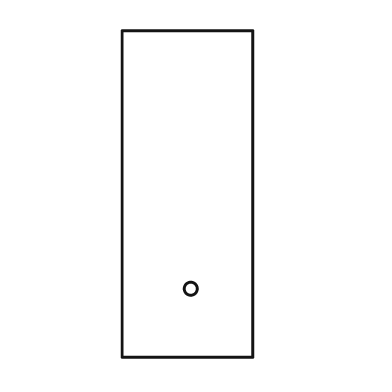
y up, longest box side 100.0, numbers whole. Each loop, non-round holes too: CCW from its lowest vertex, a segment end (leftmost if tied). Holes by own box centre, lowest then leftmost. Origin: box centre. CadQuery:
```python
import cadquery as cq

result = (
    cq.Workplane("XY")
    .moveTo(-20.0, -50.0)
    .lineTo(20.0, -50.0)
    .lineTo(20.0, 50.0)
    .lineTo(-20.0, 50.0)
    .close()
    .moveTo(1.0, -29.0)
    .circle(2.0)
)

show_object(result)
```